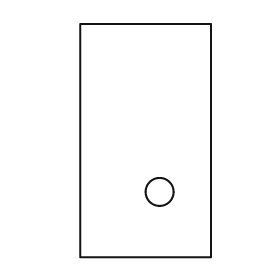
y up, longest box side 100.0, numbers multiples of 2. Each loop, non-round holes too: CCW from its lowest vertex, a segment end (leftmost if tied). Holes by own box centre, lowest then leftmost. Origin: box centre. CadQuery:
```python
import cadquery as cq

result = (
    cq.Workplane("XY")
    .moveTo(-28.0, -50.0)
    .lineTo(28.0, -50.0)
    .lineTo(28.0, 50.0)
    .lineTo(-28.0, 50.0)
    .close()
    .moveTo(6.0, -22.0)
    .circle(6.0)
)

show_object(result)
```